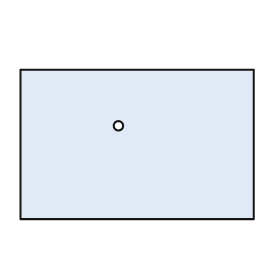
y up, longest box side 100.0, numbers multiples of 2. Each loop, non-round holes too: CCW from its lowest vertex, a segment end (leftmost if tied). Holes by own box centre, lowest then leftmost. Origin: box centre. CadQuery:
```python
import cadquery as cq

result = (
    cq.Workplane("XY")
    .moveTo(-50.0, -32.0)
    .lineTo(50.0, -32.0)
    .lineTo(50.0, 32.0)
    .lineTo(-50.0, 32.0)
    .close()
    .moveTo(-8.0, 8.0)
    .circle(2.0)
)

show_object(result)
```